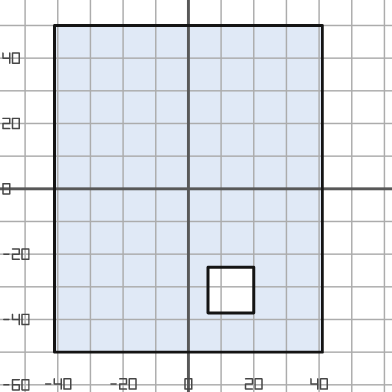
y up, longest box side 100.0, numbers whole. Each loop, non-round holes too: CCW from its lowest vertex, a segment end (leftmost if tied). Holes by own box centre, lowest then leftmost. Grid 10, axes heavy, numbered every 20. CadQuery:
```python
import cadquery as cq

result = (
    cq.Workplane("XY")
    .moveTo(-41.0, -50.0)
    .lineTo(41.0, -50.0)
    .lineTo(41.0, 50.0)
    .lineTo(-41.0, 50.0)
    .close()
    .moveTo(6.0, -38.0)
    .lineTo(20.0, -38.0)
    .lineTo(20.0, -24.0)
    .lineTo(6.0, -24.0)
    .close()
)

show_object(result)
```